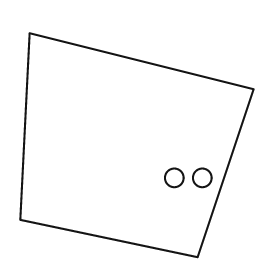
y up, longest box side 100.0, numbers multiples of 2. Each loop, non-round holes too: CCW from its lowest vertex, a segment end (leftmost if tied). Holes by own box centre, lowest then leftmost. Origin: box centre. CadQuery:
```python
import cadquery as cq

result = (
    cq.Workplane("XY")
    .moveTo(26.0, -48.0)
    .lineTo(50.0, 24.0)
    .lineTo(-46.0, 48.0)
    .lineTo(-50.0, -32.0)
    .close()
    .moveTo(16.0, -14.0)
    .circle(4.0)
    .moveTo(28.0, -14.0)
    .circle(4.0)
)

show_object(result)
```